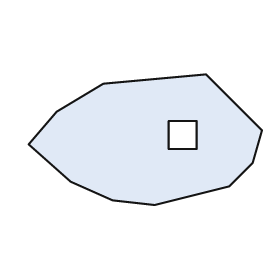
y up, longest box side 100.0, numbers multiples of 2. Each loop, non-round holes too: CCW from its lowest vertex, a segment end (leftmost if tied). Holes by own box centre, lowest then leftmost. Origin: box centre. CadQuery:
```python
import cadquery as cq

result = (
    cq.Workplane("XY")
    .moveTo(4.0, -28.0)
    .lineTo(36.0, -20.0)
    .lineTo(46.0, -10.0)
    .lineTo(50.0, 4.0)
    .lineTo(26.0, 28.0)
    .lineTo(-18.0, 24.0)
    .lineTo(-38.0, 12.0)
    .lineTo(-50.0, -2.0)
    .lineTo(-32.0, -18.0)
    .lineTo(-14.0, -26.0)
    .close()
    .moveTo(10.0, -4.0)
    .lineTo(22.0, -4.0)
    .lineTo(22.0, 8.0)
    .lineTo(10.0, 8.0)
    .close()
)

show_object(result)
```